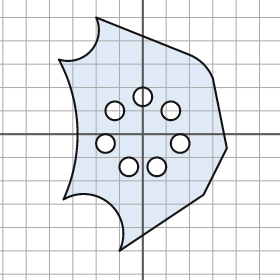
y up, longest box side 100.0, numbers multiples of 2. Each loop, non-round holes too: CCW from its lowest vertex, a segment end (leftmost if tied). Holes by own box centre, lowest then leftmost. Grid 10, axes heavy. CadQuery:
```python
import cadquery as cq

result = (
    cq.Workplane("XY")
    .moveTo(-10.0, -50.0)
    .lineTo(26.0, -26.0)
    .lineTo(36.0, -6.0)
    .lineTo(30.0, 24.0)
    .threePointArc((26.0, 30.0), (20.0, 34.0))
    .lineTo(-20.0, 50.0)
    .threePointArc((-22.0, 36.0), (-36.0, 32.0))
    .threePointArc((-28.0, 2.0), (-34.0, -28.0))
    .threePointArc((-14.0, -30.0), (-10.0, -50.0))
    .close()
    .moveTo(-6.0, -14.0)
    .circle(4.0)
    .moveTo(6.0, -14.0)
    .circle(4.0)
    .moveTo(-16.0, -4.0)
    .circle(4.0)
    .moveTo(16.0, -4.0)
    .circle(4.0)
    .moveTo(-12.0, 10.0)
    .circle(4.0)
    .moveTo(12.0, 10.0)
    .circle(4.0)
    .moveTo(0.0, 16.0)
    .circle(4.0)
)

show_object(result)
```